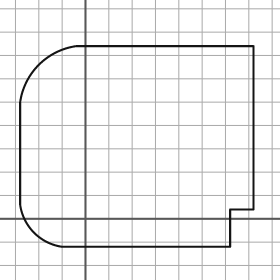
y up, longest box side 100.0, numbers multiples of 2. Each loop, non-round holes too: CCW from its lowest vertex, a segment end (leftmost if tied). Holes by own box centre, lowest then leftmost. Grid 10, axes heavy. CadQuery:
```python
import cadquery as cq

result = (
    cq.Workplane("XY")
    .moveTo(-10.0, -12.0)
    .lineTo(62.0, -12.0)
    .lineTo(62.0, 4.0)
    .lineTo(72.0, 4.0)
    .lineTo(72.0, 74.0)
    .lineTo(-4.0, 74.0)
    .threePointArc((-20.0, 66.0), (-28.0, 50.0))
    .lineTo(-28.0, 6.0)
    .threePointArc((-22.0, -6.0), (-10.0, -12.0))
    .close()
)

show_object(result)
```